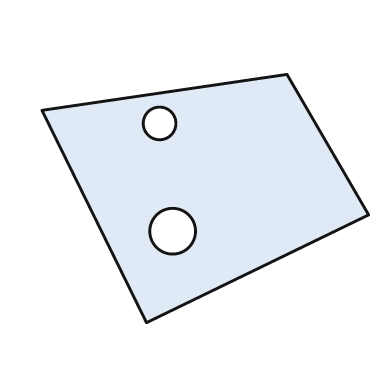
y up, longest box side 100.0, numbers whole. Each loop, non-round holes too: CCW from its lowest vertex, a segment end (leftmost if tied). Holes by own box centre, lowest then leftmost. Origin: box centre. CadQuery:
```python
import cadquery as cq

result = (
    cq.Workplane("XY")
    .moveTo(-18.0, -38.0)
    .lineTo(50.0, -5.0)
    .lineTo(25.0, 38.0)
    .lineTo(-50.0, 27.0)
    .close()
    .moveTo(-10.0, -10.0)
    .circle(7.0)
    .moveTo(-14.0, 23.0)
    .circle(5.0)
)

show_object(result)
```